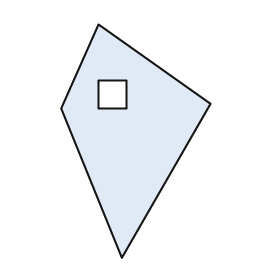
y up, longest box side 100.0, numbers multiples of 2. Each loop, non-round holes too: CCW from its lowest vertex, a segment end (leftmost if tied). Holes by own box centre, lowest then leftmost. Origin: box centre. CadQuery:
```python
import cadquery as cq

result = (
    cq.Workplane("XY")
    .moveTo(-6.0, -50.0)
    .lineTo(32.0, 16.0)
    .lineTo(-16.0, 50.0)
    .lineTo(-32.0, 14.0)
    .close()
    .moveTo(-16.0, 14.0)
    .lineTo(-4.0, 14.0)
    .lineTo(-4.0, 26.0)
    .lineTo(-16.0, 26.0)
    .close()
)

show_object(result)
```